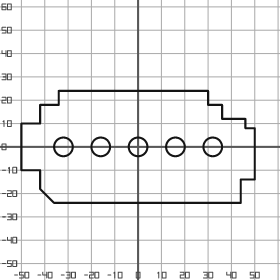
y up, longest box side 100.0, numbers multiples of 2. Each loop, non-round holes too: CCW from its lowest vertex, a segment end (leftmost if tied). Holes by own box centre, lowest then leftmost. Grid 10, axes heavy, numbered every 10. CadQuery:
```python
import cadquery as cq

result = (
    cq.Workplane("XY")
    .moveTo(-36.0, -24.0)
    .lineTo(44.0, -24.0)
    .lineTo(44.0, -14.0)
    .lineTo(50.0, -14.0)
    .lineTo(50.0, 8.0)
    .lineTo(46.0, 8.0)
    .lineTo(46.0, 12.0)
    .lineTo(36.0, 12.0)
    .lineTo(36.0, 18.0)
    .lineTo(30.0, 18.0)
    .lineTo(30.0, 24.0)
    .lineTo(-34.0, 24.0)
    .lineTo(-34.0, 18.0)
    .lineTo(-42.0, 18.0)
    .lineTo(-42.0, 10.0)
    .lineTo(-50.0, 10.0)
    .lineTo(-50.0, -10.0)
    .lineTo(-42.0, -10.0)
    .lineTo(-42.0, -18.0)
    .close()
    .moveTo(-32.0, 0.0)
    .circle(4.0)
    .moveTo(-16.0, 0.0)
    .circle(4.0)
    .moveTo(0.0, 0.0)
    .circle(4.0)
    .moveTo(16.0, 0.0)
    .circle(4.0)
    .moveTo(32.0, 0.0)
    .circle(4.0)
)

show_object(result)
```